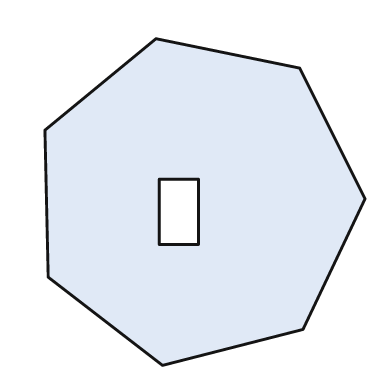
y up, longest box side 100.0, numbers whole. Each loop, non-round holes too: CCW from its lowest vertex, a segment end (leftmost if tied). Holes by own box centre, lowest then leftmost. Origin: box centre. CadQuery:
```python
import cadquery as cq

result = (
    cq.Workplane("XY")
    .moveTo(-13.0, -50.0)
    .lineTo(30.0, -39.0)
    .lineTo(49.0, 1.0)
    .lineTo(29.0, 41.0)
    .lineTo(-15.0, 50.0)
    .lineTo(-49.0, 22.0)
    .lineTo(-48.0, -23.0)
    .close()
    .moveTo(-14.0, -13.0)
    .lineTo(-2.0, -13.0)
    .lineTo(-2.0, 7.0)
    .lineTo(-14.0, 7.0)
    .close()
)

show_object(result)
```